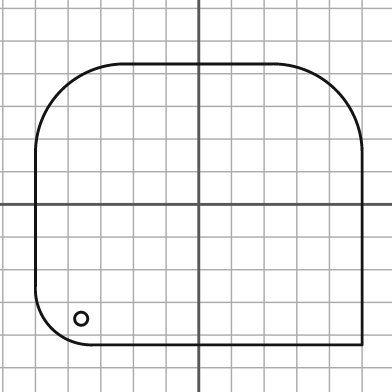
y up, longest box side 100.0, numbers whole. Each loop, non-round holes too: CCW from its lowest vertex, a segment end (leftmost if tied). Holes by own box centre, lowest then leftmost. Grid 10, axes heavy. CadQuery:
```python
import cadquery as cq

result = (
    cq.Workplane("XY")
    .moveTo(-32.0, -43.0)
    .lineTo(50.0, -43.0)
    .lineTo(50.0, 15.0)
    .threePointArc((42.0, 35.0), (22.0, 43.0))
    .lineTo(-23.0, 43.0)
    .threePointArc((-42.0, 35.0), (-50.0, 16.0))
    .lineTo(-50.0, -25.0)
    .threePointArc((-45.0, -38.0), (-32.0, -43.0))
    .close()
    .moveTo(-36.0, -35.0)
    .circle(2.0)
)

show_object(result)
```